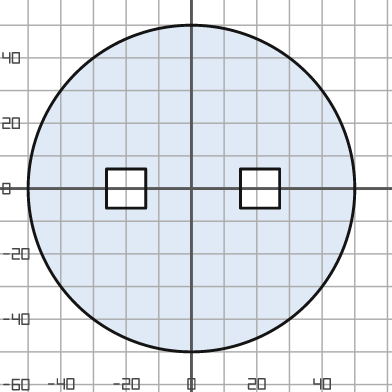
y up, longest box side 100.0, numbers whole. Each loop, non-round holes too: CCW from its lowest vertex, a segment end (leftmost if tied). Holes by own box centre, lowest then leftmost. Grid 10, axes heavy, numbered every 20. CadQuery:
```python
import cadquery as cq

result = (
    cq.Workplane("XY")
    .moveTo(0.0, 0.0)
    .circle(50.0)
    .moveTo(-26.0, -6.0)
    .lineTo(-14.0, -6.0)
    .lineTo(-14.0, 6.0)
    .lineTo(-26.0, 6.0)
    .close()
    .moveTo(15.0, -6.0)
    .lineTo(27.0, -6.0)
    .lineTo(27.0, 6.0)
    .lineTo(15.0, 6.0)
    .close()
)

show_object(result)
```